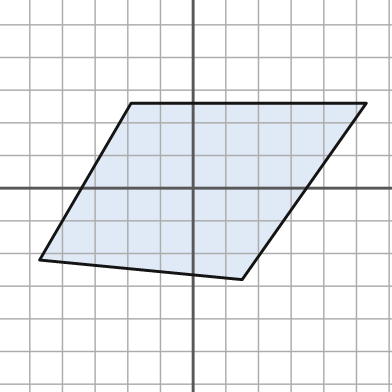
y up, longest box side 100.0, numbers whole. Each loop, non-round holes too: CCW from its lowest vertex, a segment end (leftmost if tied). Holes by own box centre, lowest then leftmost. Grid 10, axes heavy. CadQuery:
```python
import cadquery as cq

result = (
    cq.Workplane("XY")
    .moveTo(15.0, -28.0)
    .lineTo(53.0, 26.0)
    .lineTo(-19.0, 26.0)
    .lineTo(-47.0, -22.0)
    .close()
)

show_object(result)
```